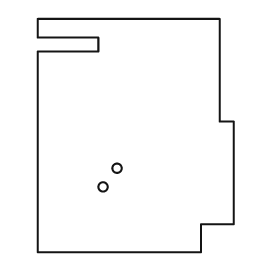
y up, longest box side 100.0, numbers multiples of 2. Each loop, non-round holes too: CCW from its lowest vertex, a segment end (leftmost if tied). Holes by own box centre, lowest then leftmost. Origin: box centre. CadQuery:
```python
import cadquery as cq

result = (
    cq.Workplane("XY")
    .moveTo(-42.0, -50.0)
    .lineTo(28.0, -50.0)
    .lineTo(28.0, -38.0)
    .lineTo(42.0, -38.0)
    .lineTo(42.0, 6.0)
    .lineTo(36.0, 6.0)
    .lineTo(36.0, 50.0)
    .lineTo(-42.0, 50.0)
    .lineTo(-42.0, 42.0)
    .lineTo(-16.0, 42.0)
    .lineTo(-16.0, 36.0)
    .lineTo(-42.0, 36.0)
    .close()
    .moveTo(-14.0, -22.0)
    .circle(2.0)
    .moveTo(-8.0, -14.0)
    .circle(2.0)
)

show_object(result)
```